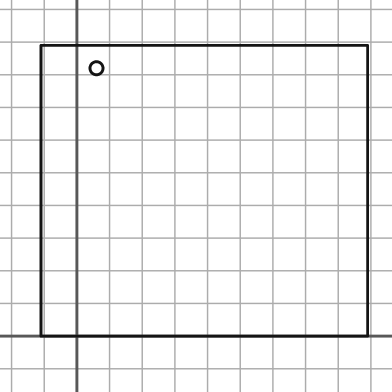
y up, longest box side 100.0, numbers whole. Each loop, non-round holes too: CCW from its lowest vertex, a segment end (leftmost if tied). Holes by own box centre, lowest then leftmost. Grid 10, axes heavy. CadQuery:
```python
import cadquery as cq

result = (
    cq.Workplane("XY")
    .moveTo(-11.0, 0.0)
    .lineTo(89.0, 0.0)
    .lineTo(89.0, 89.0)
    .lineTo(-11.0, 89.0)
    .close()
    .moveTo(6.0, 82.0)
    .circle(2.0)
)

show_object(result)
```